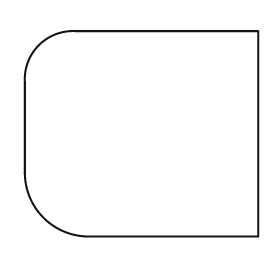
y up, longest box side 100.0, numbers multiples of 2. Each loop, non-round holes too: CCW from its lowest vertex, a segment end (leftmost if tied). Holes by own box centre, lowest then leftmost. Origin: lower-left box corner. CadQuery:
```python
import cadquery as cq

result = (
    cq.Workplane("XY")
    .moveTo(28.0, 0.0)
    .lineTo(100.0, 0.0)
    .lineTo(100.0, 88.0)
    .lineTo(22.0, 88.0)
    .threePointArc((6.0, 82.0), (0.0, 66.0))
    .lineTo(0.0, 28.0)
    .threePointArc((8.0, 8.0), (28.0, 0.0))
    .close()
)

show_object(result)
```